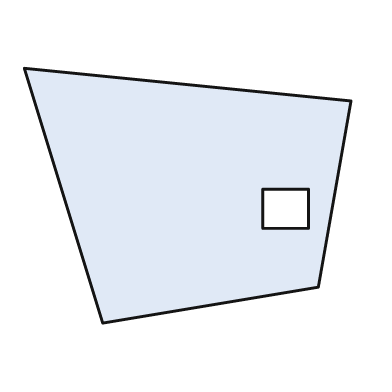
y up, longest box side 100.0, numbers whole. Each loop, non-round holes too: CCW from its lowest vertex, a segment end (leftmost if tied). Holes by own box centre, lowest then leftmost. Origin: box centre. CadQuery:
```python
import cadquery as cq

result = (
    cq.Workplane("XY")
    .moveTo(-26.0, -39.0)
    .lineTo(40.0, -28.0)
    .lineTo(50.0, 29.0)
    .lineTo(-50.0, 39.0)
    .close()
    .moveTo(23.0, -10.0)
    .lineTo(37.0, -10.0)
    .lineTo(37.0, 2.0)
    .lineTo(23.0, 2.0)
    .close()
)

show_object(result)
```